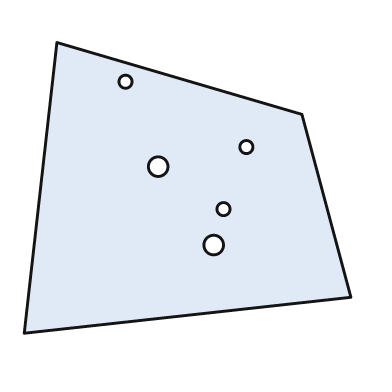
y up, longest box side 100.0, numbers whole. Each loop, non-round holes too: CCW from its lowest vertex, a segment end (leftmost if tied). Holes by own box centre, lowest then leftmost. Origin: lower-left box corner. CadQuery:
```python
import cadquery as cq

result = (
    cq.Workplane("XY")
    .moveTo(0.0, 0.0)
    .lineTo(100.0, 11.0)
    .lineTo(85.0, 67.0)
    .lineTo(10.0, 89.0)
    .close()
    .moveTo(58.0, 27.0)
    .circle(3.0)
    .moveTo(61.0, 38.0)
    .circle(2.0)
    .moveTo(41.0, 51.0)
    .circle(3.0)
    .moveTo(68.0, 57.0)
    .circle(2.0)
    .moveTo(31.0, 77.0)
    .circle(2.0)
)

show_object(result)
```